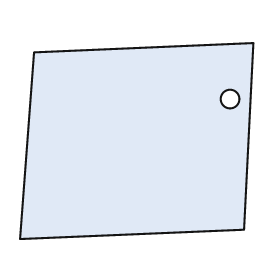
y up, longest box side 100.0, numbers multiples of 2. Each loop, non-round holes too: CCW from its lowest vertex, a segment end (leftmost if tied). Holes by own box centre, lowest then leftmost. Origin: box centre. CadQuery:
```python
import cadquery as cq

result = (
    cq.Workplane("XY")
    .moveTo(-50.0, -42.0)
    .lineTo(46.0, -38.0)
    .lineTo(50.0, 42.0)
    .lineTo(-44.0, 38.0)
    .close()
    .moveTo(40.0, 18.0)
    .circle(4.0)
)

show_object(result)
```